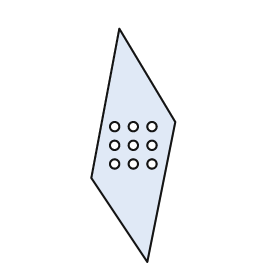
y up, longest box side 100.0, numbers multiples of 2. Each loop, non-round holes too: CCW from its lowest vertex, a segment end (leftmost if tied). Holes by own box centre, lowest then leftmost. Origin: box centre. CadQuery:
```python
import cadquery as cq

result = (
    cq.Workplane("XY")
    .moveTo(6.0, -50.0)
    .lineTo(18.0, 10.0)
    .lineTo(-6.0, 50.0)
    .lineTo(-18.0, -14.0)
    .close()
    .moveTo(-8.0, -8.0)
    .circle(2.0)
    .moveTo(0.0, -8.0)
    .circle(2.0)
    .moveTo(8.0, -8.0)
    .circle(2.0)
    .moveTo(-8.0, 0.0)
    .circle(2.0)
    .moveTo(0.0, 0.0)
    .circle(2.0)
    .moveTo(8.0, 0.0)
    .circle(2.0)
    .moveTo(-8.0, 8.0)
    .circle(2.0)
    .moveTo(0.0, 8.0)
    .circle(2.0)
    .moveTo(8.0, 8.0)
    .circle(2.0)
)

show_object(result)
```